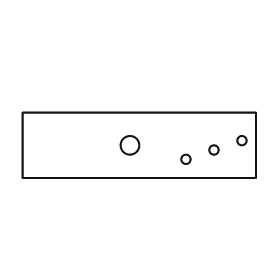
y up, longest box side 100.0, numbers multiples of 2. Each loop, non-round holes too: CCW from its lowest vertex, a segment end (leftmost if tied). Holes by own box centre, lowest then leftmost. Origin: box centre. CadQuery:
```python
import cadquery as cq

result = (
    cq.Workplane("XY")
    .moveTo(-50.0, -14.0)
    .lineTo(50.0, -14.0)
    .lineTo(50.0, 14.0)
    .lineTo(-50.0, 14.0)
    .close()
    .moveTo(20.0, -6.0)
    .circle(2.0)
    .moveTo(32.0, -2.0)
    .circle(2.0)
    .moveTo(-4.0, 0.0)
    .circle(4.0)
    .moveTo(44.0, 2.0)
    .circle(2.0)
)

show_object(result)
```